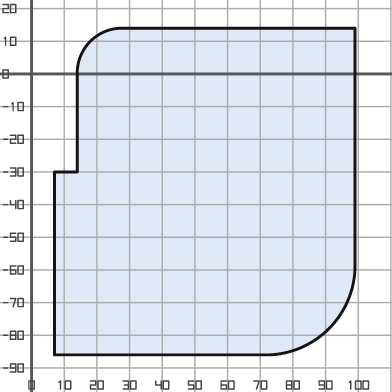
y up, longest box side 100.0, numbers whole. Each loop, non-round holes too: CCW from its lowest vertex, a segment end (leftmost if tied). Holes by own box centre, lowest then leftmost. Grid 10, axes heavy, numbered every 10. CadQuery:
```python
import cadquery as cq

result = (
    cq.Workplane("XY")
    .moveTo(7.0, -86.0)
    .lineTo(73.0, -86.0)
    .threePointArc((91.0, -78.0), (99.0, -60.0))
    .lineTo(99.0, 14.0)
    .lineTo(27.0, 14.0)
    .threePointArc((18.0, 10.0), (14.0, 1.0))
    .lineTo(14.0, -30.0)
    .lineTo(7.0, -30.0)
    .close()
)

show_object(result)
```